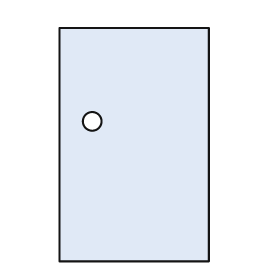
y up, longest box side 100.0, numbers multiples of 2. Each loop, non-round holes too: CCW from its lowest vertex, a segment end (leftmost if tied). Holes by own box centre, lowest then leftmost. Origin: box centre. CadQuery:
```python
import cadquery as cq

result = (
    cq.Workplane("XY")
    .moveTo(-32.0, -50.0)
    .lineTo(32.0, -50.0)
    .lineTo(32.0, 50.0)
    .lineTo(-32.0, 50.0)
    .close()
    .moveTo(-18.0, 10.0)
    .circle(4.0)
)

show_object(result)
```